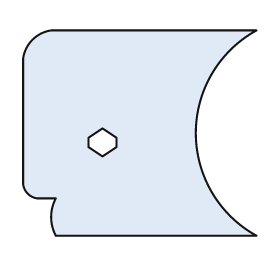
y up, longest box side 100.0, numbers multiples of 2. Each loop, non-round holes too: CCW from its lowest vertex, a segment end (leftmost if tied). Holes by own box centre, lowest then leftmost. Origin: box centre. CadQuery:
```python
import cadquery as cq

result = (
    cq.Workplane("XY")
    .moveTo(-36.0, -44.0)
    .lineTo(50.0, -44.0)
    .threePointArc((24.0, 0.0), (50.0, 44.0))
    .lineTo(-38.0, 44.0)
    .threePointArc((-46.0, 40.0), (-50.0, 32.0))
    .lineTo(-50.0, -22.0)
    .threePointArc((-48.0, -26.0), (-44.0, -28.0))
    .lineTo(-36.0, -28.0)
    .threePointArc((-38.0, -36.0), (-36.0, -44.0))
    .close()
    .moveTo(-16.0, -10.0)
    .lineTo(-10.0, -6.0)
    .lineTo(-10.0, -2.0)
    .lineTo(-16.0, 2.0)
    .lineTo(-22.0, -2.0)
    .lineTo(-22.0, -6.0)
    .close()
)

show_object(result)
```